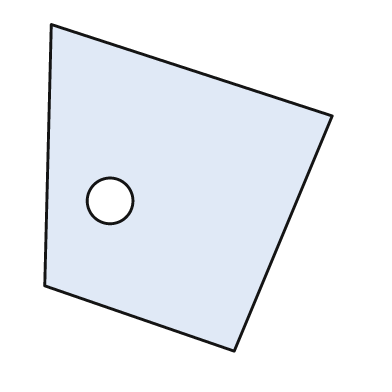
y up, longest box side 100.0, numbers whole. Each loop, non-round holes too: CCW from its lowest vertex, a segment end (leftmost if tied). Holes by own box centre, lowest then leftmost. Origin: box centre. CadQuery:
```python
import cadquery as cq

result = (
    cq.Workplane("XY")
    .moveTo(14.0, -50.0)
    .lineTo(44.0, 22.0)
    .lineTo(-42.0, 50.0)
    .lineTo(-44.0, -30.0)
    .close()
    .moveTo(-24.0, -4.0)
    .circle(7.0)
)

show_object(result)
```